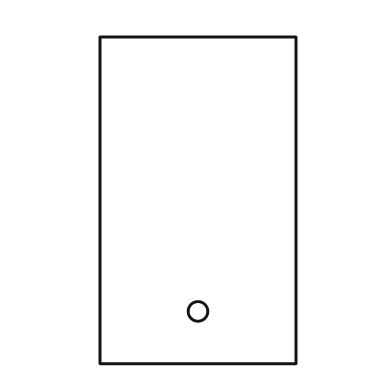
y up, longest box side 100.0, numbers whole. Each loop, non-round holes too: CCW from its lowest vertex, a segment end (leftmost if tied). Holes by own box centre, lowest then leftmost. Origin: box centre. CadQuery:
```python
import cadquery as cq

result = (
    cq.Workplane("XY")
    .moveTo(-30.0, -50.0)
    .lineTo(30.0, -50.0)
    .lineTo(30.0, 50.0)
    .lineTo(-30.0, 50.0)
    .close()
    .moveTo(0.0, -34.0)
    .circle(3.0)
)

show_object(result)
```